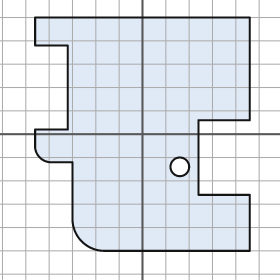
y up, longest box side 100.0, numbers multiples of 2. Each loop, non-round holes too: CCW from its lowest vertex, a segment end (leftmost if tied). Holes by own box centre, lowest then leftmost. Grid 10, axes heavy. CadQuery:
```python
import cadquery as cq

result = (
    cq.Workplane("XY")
    .moveTo(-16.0, -50.0)
    .lineTo(46.0, -50.0)
    .lineTo(46.0, -26.0)
    .lineTo(24.0, -26.0)
    .lineTo(24.0, 6.0)
    .lineTo(46.0, 6.0)
    .lineTo(46.0, 50.0)
    .lineTo(-46.0, 50.0)
    .lineTo(-46.0, 38.0)
    .lineTo(-32.0, 38.0)
    .lineTo(-32.0, 2.0)
    .lineTo(-46.0, 2.0)
    .lineTo(-46.0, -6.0)
    .threePointArc((-44.0, -10.0), (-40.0, -12.0))
    .lineTo(-30.0, -12.0)
    .lineTo(-30.0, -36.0)
    .threePointArc((-26.0, -46.0), (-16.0, -50.0))
    .close()
    .moveTo(16.0, -14.0)
    .circle(4.0)
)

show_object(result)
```